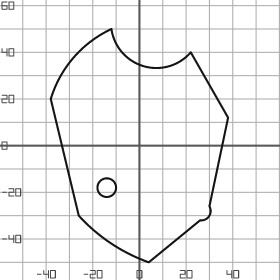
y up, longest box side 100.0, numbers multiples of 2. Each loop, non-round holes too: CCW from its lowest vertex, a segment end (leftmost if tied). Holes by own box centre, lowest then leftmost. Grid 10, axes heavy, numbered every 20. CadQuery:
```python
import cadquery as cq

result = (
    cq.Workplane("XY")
    .moveTo(4.0, -50.0)
    .lineTo(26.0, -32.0)
    .threePointArc((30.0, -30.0), (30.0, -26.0))
    .lineTo(38.0, 12.0)
    .lineTo(22.0, 40.0)
    .threePointArc((2.0, 34.0), (-12.0, 50.0))
    .threePointArc((-28.0, 38.0), (-38.0, 20.0))
    .lineTo(-26.0, -30.0)
    .threePointArc((-12.0, -42.0), (4.0, -50.0))
    .close()
    .moveTo(-14.0, -18.0)
    .circle(4.0)
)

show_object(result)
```